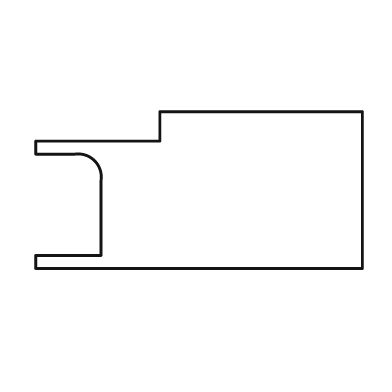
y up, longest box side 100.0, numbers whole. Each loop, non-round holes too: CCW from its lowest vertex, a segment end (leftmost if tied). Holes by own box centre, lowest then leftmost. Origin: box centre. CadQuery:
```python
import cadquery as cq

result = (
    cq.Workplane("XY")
    .moveTo(-50.0, -24.0)
    .lineTo(50.0, -24.0)
    .lineTo(50.0, 24.0)
    .lineTo(-12.0, 24.0)
    .lineTo(-12.0, 15.0)
    .lineTo(-50.0, 15.0)
    .lineTo(-50.0, 11.0)
    .lineTo(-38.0, 11.0)
    .threePointArc((-32.0, 9.0), (-30.0, 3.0))
    .lineTo(-30.0, -20.0)
    .lineTo(-50.0, -20.0)
    .close()
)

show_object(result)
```